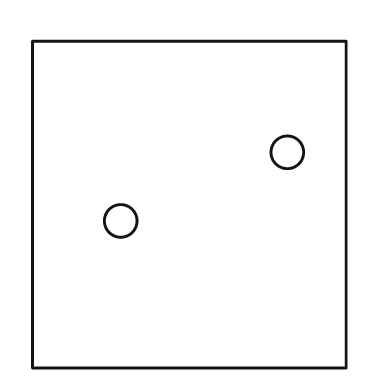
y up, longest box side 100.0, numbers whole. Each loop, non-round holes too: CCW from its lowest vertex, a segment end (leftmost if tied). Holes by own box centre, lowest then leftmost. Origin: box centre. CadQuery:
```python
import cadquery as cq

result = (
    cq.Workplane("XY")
    .moveTo(-48.0, -50.0)
    .lineTo(48.0, -50.0)
    .lineTo(48.0, 50.0)
    .lineTo(-48.0, 50.0)
    .close()
    .moveTo(-21.0, -5.0)
    .circle(5.0)
    .moveTo(30.0, 16.0)
    .circle(5.0)
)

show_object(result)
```